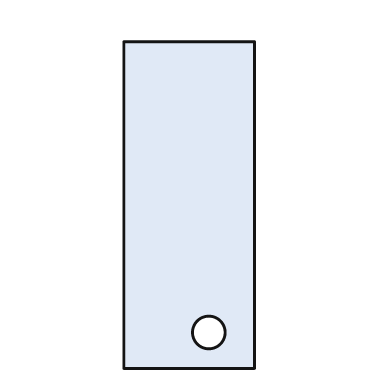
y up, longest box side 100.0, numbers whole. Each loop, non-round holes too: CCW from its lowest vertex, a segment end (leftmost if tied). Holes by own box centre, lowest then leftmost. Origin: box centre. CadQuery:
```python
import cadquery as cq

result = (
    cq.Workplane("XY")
    .moveTo(-20.0, -50.0)
    .lineTo(20.0, -50.0)
    .lineTo(20.0, 50.0)
    .lineTo(-20.0, 50.0)
    .close()
    .moveTo(6.0, -39.0)
    .circle(5.0)
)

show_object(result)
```